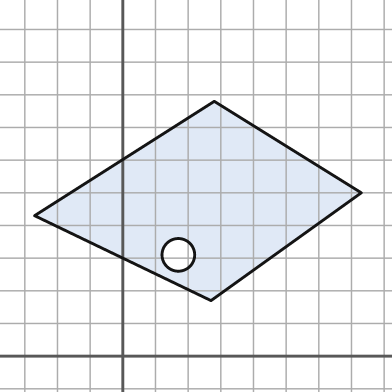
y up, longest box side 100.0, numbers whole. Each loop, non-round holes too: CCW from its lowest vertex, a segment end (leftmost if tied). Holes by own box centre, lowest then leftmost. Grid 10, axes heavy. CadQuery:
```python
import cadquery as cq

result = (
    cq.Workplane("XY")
    .moveTo(27.0, 17.0)
    .lineTo(73.0, 50.0)
    .lineTo(28.0, 78.0)
    .lineTo(-27.0, 43.0)
    .close()
    .moveTo(17.0, 31.0)
    .circle(5.0)
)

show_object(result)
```